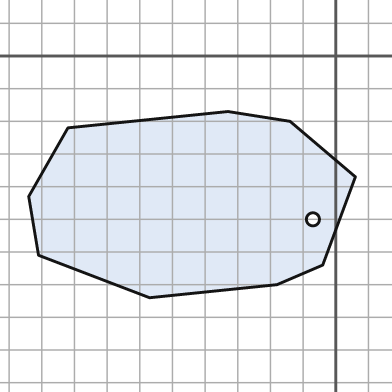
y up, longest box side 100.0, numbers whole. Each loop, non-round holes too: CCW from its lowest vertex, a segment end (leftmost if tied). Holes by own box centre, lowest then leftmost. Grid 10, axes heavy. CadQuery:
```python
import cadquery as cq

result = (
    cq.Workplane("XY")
    .moveTo(-57.0, -74.0)
    .lineTo(-18.0, -70.0)
    .lineTo(-4.0, -64.0)
    .lineTo(6.0, -37.0)
    .lineTo(-14.0, -20.0)
    .lineTo(-33.0, -17.0)
    .lineTo(-82.0, -22.0)
    .lineTo(-94.0, -43.0)
    .lineTo(-91.0, -61.0)
    .close()
    .moveTo(-7.0, -50.0)
    .circle(2.0)
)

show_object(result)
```